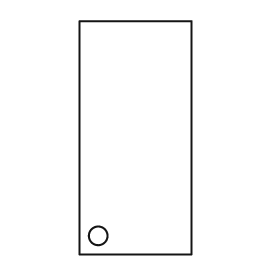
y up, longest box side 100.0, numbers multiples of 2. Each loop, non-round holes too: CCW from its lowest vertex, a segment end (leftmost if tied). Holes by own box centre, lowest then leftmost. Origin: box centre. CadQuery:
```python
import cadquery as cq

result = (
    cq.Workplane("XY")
    .moveTo(-24.0, -50.0)
    .lineTo(24.0, -50.0)
    .lineTo(24.0, 50.0)
    .lineTo(-24.0, 50.0)
    .close()
    .moveTo(-16.0, -42.0)
    .circle(4.0)
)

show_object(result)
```